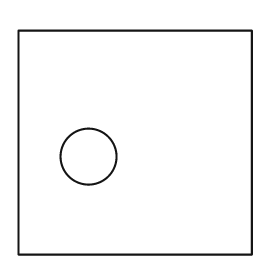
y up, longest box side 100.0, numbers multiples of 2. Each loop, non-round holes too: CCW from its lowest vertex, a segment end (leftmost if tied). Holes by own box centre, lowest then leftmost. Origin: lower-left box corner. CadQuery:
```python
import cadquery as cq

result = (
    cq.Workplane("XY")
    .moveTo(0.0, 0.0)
    .lineTo(100.0, 0.0)
    .lineTo(100.0, 96.0)
    .lineTo(0.0, 96.0)
    .close()
    .moveTo(30.0, 42.0)
    .circle(12.0)
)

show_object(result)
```